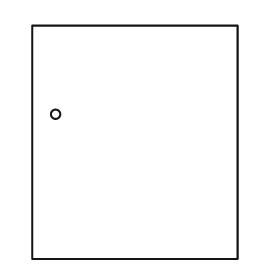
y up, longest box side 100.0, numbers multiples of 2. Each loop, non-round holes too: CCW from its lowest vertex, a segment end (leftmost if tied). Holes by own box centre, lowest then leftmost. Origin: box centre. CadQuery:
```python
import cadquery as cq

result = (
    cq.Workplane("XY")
    .moveTo(-44.0, -50.0)
    .lineTo(44.0, -50.0)
    .lineTo(44.0, 50.0)
    .lineTo(-44.0, 50.0)
    .close()
    .moveTo(-34.0, 12.0)
    .circle(2.0)
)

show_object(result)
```